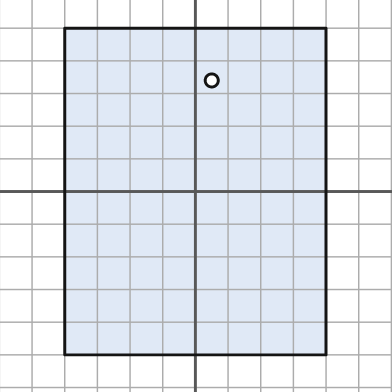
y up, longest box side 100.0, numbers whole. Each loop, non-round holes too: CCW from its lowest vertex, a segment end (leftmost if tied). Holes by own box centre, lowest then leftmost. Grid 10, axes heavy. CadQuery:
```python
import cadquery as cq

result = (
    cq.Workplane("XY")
    .moveTo(-40.0, -50.0)
    .lineTo(40.0, -50.0)
    .lineTo(40.0, 50.0)
    .lineTo(-40.0, 50.0)
    .close()
    .moveTo(5.0, 34.0)
    .circle(2.0)
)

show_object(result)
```